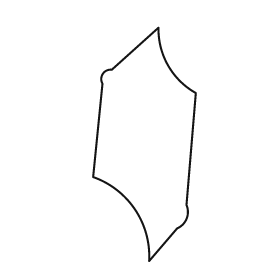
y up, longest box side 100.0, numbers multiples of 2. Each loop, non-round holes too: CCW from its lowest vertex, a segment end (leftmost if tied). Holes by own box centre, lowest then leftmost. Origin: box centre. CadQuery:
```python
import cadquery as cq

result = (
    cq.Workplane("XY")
    .moveTo(2.0, -50.0)
    .lineTo(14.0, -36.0)
    .threePointArc((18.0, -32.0), (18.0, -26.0))
    .lineTo(22.0, 22.0)
    .threePointArc((10.0, 34.0), (6.0, 50.0))
    .lineTo(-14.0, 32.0)
    .threePointArc((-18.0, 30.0), (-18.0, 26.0))
    .lineTo(-22.0, -14.0)
    .threePointArc((-4.0, -28.0), (2.0, -50.0))
    .close()
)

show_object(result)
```